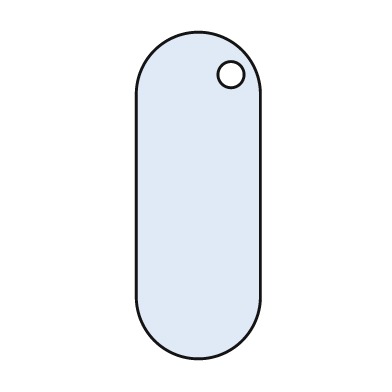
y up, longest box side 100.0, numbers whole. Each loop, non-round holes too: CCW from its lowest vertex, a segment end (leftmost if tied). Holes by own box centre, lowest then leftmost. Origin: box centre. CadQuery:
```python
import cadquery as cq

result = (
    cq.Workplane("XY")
    .moveTo(-19.0, -31.0)
    .threePointArc((0.0, -50.0), (19.0, -31.0))
    .lineTo(19.0, 31.0)
    .threePointArc((0.0, 50.0), (-19.0, 31.0))
    .close()
    .moveTo(10.0, 37.0)
    .circle(4.0)
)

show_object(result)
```